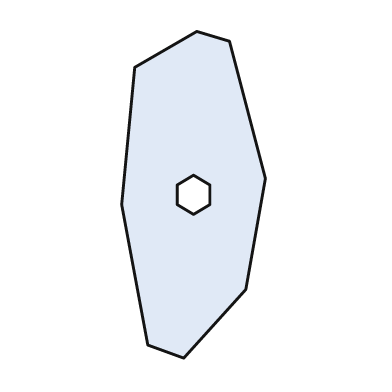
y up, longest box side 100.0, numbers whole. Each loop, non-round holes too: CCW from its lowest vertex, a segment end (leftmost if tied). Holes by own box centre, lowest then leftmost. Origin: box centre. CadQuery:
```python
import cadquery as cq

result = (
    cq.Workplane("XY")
    .moveTo(-3.0, -50.0)
    .lineTo(16.0, -29.0)
    .lineTo(22.0, 5.0)
    .lineTo(11.0, 47.0)
    .lineTo(1.0, 50.0)
    .lineTo(-18.0, 39.0)
    .lineTo(-22.0, -3.0)
    .lineTo(-14.0, -46.0)
    .close()
    .moveTo(0.0, -6.0)
    .lineTo(5.0, -3.0)
    .lineTo(5.0, 3.0)
    .lineTo(0.0, 6.0)
    .lineTo(-5.0, 3.0)
    .lineTo(-5.0, -3.0)
    .close()
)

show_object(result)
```